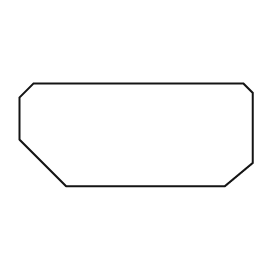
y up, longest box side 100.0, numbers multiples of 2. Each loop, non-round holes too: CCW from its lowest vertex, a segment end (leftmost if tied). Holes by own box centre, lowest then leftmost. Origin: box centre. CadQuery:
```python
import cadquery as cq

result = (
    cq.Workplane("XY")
    .moveTo(-30.0, -22.0)
    .lineTo(38.0, -22.0)
    .lineTo(50.0, -12.0)
    .lineTo(50.0, 18.0)
    .lineTo(46.0, 22.0)
    .lineTo(-44.0, 22.0)
    .lineTo(-50.0, 16.0)
    .lineTo(-50.0, -2.0)
    .close()
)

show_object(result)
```